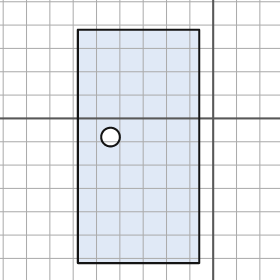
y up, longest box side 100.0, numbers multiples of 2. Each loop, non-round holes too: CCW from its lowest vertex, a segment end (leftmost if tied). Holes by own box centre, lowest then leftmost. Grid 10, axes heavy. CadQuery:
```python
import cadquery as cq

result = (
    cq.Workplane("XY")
    .moveTo(-58.0, -62.0)
    .lineTo(-6.0, -62.0)
    .lineTo(-6.0, 38.0)
    .lineTo(-58.0, 38.0)
    .close()
    .moveTo(-44.0, -8.0)
    .circle(4.0)
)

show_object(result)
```